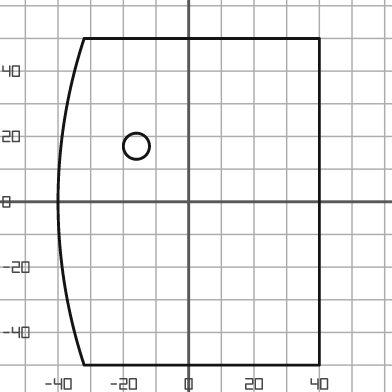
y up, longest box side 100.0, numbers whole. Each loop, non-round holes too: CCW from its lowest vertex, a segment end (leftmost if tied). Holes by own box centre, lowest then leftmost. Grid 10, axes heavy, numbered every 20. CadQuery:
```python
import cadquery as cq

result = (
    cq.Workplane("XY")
    .moveTo(-32.0, -50.0)
    .lineTo(40.0, -50.0)
    .lineTo(40.0, 50.0)
    .lineTo(-32.0, 50.0)
    .threePointArc((-40.0, 0.0), (-32.0, -50.0))
    .close()
    .moveTo(-16.0, 17.0)
    .circle(4.0)
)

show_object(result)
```